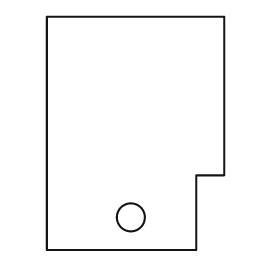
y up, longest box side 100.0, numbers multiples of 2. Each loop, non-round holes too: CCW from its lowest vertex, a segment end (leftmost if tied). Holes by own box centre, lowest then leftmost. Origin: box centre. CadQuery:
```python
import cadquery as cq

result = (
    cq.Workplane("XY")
    .moveTo(-38.0, -50.0)
    .lineTo(26.0, -50.0)
    .lineTo(26.0, -18.0)
    .lineTo(38.0, -18.0)
    .lineTo(38.0, 50.0)
    .lineTo(-38.0, 50.0)
    .close()
    .moveTo(-2.0, -36.0)
    .circle(6.0)
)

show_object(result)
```